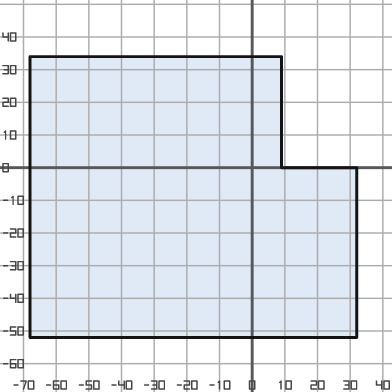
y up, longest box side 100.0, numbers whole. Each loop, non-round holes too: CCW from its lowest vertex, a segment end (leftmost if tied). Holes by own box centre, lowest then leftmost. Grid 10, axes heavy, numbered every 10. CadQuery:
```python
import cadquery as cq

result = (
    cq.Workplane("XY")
    .moveTo(-68.0, -52.0)
    .lineTo(32.0, -52.0)
    .lineTo(32.0, 0.0)
    .lineTo(9.0, 0.0)
    .lineTo(9.0, 34.0)
    .lineTo(-68.0, 34.0)
    .close()
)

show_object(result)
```